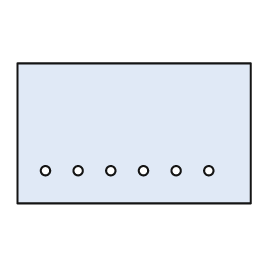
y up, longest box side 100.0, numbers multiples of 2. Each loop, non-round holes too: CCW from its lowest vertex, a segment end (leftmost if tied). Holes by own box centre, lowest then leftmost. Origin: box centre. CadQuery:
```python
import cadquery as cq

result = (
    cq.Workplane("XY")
    .moveTo(-50.0, -30.0)
    .lineTo(50.0, -30.0)
    .lineTo(50.0, 30.0)
    .lineTo(-50.0, 30.0)
    .close()
    .moveTo(-38.0, -16.0)
    .circle(2.0)
    .moveTo(-24.0, -16.0)
    .circle(2.0)
    .moveTo(-10.0, -16.0)
    .circle(2.0)
    .moveTo(4.0, -16.0)
    .circle(2.0)
    .moveTo(18.0, -16.0)
    .circle(2.0)
    .moveTo(32.0, -16.0)
    .circle(2.0)
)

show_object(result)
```